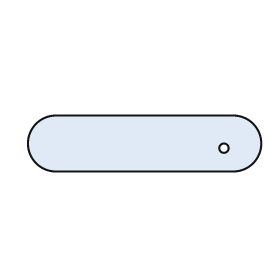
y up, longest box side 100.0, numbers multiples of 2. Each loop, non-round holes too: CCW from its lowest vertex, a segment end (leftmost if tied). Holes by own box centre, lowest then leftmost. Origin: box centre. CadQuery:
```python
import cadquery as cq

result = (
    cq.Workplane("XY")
    .moveTo(-38.0, -12.0)
    .lineTo(38.0, -12.0)
    .threePointArc((50.0, 0.0), (38.0, 12.0))
    .lineTo(-38.0, 12.0)
    .threePointArc((-50.0, 0.0), (-38.0, -12.0))
    .close()
    .moveTo(34.0, -2.0)
    .circle(2.0)
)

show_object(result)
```